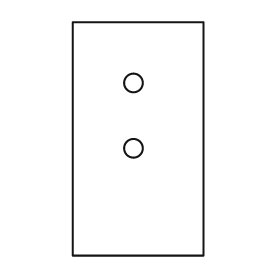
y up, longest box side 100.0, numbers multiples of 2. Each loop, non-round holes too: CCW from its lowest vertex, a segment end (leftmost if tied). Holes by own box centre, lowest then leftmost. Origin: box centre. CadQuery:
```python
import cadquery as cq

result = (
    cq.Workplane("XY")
    .moveTo(-28.0, -50.0)
    .lineTo(28.0, -50.0)
    .lineTo(28.0, 50.0)
    .lineTo(-28.0, 50.0)
    .close()
    .moveTo(-2.0, -4.0)
    .circle(4.0)
    .moveTo(-2.0, 24.0)
    .circle(4.0)
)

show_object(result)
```